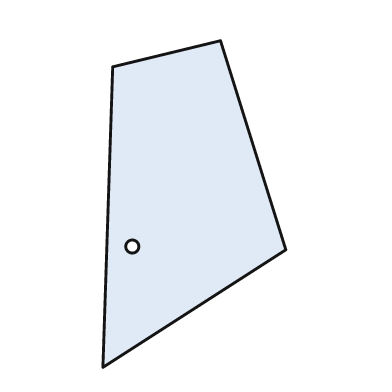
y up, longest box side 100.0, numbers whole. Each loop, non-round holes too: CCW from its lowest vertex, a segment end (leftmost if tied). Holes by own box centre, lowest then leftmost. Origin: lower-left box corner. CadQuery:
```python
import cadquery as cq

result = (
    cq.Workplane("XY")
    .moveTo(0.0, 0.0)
    .lineTo(56.0, 36.0)
    .lineTo(36.0, 100.0)
    .lineTo(3.0, 92.0)
    .close()
    .moveTo(9.0, 37.0)
    .circle(2.0)
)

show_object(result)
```